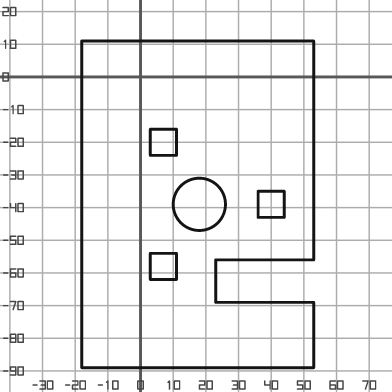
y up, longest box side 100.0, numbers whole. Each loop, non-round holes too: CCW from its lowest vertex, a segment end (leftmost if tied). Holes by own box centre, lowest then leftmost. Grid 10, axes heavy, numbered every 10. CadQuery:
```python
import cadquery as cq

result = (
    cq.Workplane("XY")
    .moveTo(-18.0, -89.0)
    .lineTo(53.0, -89.0)
    .lineTo(53.0, -69.0)
    .lineTo(23.0, -69.0)
    .lineTo(23.0, -56.0)
    .lineTo(53.0, -56.0)
    .lineTo(53.0, 11.0)
    .lineTo(-18.0, 11.0)
    .close()
    .moveTo(3.0, -62.0)
    .lineTo(11.0, -62.0)
    .lineTo(11.0, -54.0)
    .lineTo(3.0, -54.0)
    .close()
    .moveTo(18.0, -39.0)
    .circle(8.0)
    .moveTo(36.0, -43.0)
    .lineTo(44.0, -43.0)
    .lineTo(44.0, -35.0)
    .lineTo(36.0, -35.0)
    .close()
    .moveTo(3.0, -24.0)
    .lineTo(11.0, -24.0)
    .lineTo(11.0, -16.0)
    .lineTo(3.0, -16.0)
    .close()
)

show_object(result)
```